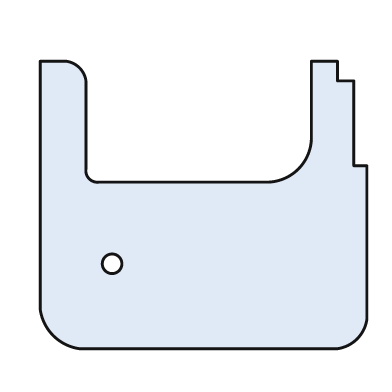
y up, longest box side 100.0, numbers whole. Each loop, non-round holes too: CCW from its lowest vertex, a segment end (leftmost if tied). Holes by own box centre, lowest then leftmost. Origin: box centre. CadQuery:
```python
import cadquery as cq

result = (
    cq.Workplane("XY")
    .moveTo(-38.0, -44.0)
    .lineTo(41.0, -44.0)
    .threePointArc((47.0, -41.0), (50.0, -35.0))
    .lineTo(50.0, 12.0)
    .lineTo(46.0, 12.0)
    .lineTo(46.0, 38.0)
    .lineTo(41.0, 38.0)
    .lineTo(41.0, 44.0)
    .lineTo(33.0, 44.0)
    .lineTo(33.0, 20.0)
    .threePointArc((29.0, 11.0), (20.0, 7.0))
    .lineTo(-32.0, 7.0)
    .threePointArc((-35.0, 8.0), (-36.0, 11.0))
    .lineTo(-36.0, 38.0)
    .threePointArc((-38.0, 42.0), (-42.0, 44.0))
    .lineTo(-50.0, 44.0)
    .lineTo(-50.0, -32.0)
    .threePointArc((-46.0, -40.0), (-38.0, -44.0))
    .close()
    .moveTo(-28.0, -18.0)
    .circle(3.0)
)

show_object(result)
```